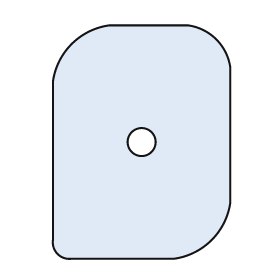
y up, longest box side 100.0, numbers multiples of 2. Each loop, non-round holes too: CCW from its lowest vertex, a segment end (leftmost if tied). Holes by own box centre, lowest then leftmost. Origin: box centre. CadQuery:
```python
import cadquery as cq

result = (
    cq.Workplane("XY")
    .moveTo(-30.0, -50.0)
    .lineTo(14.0, -50.0)
    .threePointArc((30.0, -42.0), (38.0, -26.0))
    .lineTo(38.0, 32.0)
    .threePointArc((32.0, 44.0), (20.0, 50.0))
    .lineTo(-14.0, 50.0)
    .threePointArc((-30.0, 42.0), (-38.0, 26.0))
    .lineTo(-38.0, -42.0)
    .threePointArc((-36.0, -48.0), (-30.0, -50.0))
    .close()
    .moveTo(0.0, 0.0)
    .circle(6.0)
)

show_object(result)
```